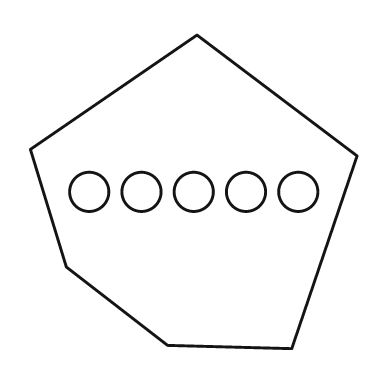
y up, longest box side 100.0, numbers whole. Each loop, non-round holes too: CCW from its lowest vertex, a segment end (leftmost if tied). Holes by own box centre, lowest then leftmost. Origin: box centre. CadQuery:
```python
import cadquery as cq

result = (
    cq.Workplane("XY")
    .moveTo(30.0, -48.0)
    .lineTo(50.0, 11.0)
    .lineTo(1.0, 48.0)
    .lineTo(-50.0, 13.0)
    .lineTo(-39.0, -23.0)
    .lineTo(-8.0, -47.0)
    .close()
    .moveTo(-32.0, 0.0)
    .circle(6.0)
    .moveTo(-16.0, 0.0)
    .circle(6.0)
    .moveTo(0.0, 0.0)
    .circle(6.0)
    .moveTo(16.0, 0.0)
    .circle(6.0)
    .moveTo(32.0, 0.0)
    .circle(6.0)
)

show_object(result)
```